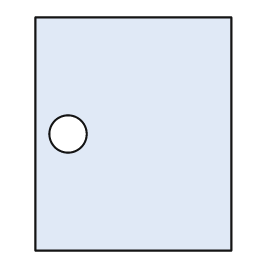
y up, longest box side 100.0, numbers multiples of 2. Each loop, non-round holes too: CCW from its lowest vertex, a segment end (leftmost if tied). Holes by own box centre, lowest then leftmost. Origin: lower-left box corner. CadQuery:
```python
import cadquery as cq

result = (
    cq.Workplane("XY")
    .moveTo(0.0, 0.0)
    .lineTo(84.0, 0.0)
    .lineTo(84.0, 100.0)
    .lineTo(0.0, 100.0)
    .close()
    .moveTo(14.0, 50.0)
    .circle(8.0)
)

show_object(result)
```